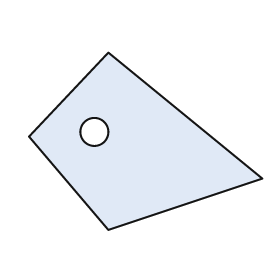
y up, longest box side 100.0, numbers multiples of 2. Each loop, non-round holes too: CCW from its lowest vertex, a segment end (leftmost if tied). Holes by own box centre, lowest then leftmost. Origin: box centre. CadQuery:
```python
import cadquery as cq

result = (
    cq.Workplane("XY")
    .moveTo(-16.0, -38.0)
    .lineTo(50.0, -16.0)
    .lineTo(-16.0, 38.0)
    .lineTo(-50.0, 2.0)
    .close()
    .moveTo(-22.0, 4.0)
    .circle(6.0)
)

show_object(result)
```